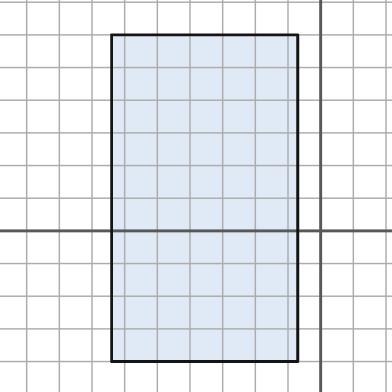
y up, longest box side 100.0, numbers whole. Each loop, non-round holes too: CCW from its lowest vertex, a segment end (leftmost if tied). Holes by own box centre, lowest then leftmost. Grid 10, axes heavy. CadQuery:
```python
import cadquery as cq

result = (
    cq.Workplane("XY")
    .moveTo(-64.0, -40.0)
    .lineTo(-7.0, -40.0)
    .lineTo(-7.0, 60.0)
    .lineTo(-64.0, 60.0)
    .close()
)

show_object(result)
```